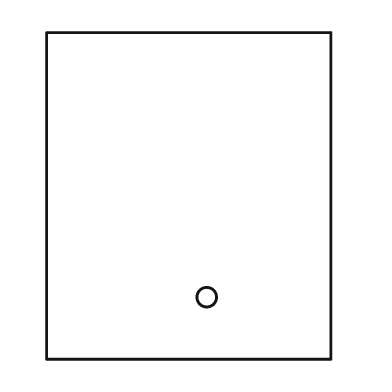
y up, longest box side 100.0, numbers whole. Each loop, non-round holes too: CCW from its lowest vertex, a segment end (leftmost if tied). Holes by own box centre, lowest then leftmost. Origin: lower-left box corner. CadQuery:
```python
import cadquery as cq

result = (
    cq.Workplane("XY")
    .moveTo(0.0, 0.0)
    .lineTo(87.0, 0.0)
    .lineTo(87.0, 100.0)
    .lineTo(0.0, 100.0)
    .close()
    .moveTo(49.0, 19.0)
    .circle(3.0)
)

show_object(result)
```